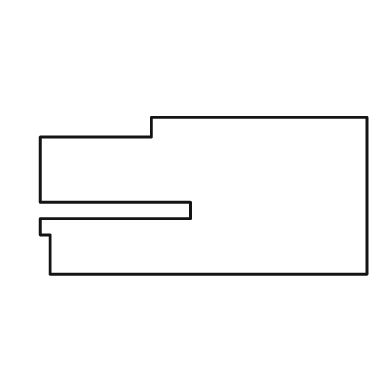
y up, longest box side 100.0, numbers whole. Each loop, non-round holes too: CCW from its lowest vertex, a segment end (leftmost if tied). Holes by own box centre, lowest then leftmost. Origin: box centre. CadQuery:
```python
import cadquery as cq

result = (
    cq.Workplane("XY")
    .moveTo(-47.0, -24.0)
    .lineTo(50.0, -24.0)
    .lineTo(50.0, 24.0)
    .lineTo(-16.0, 24.0)
    .lineTo(-16.0, 18.0)
    .lineTo(-50.0, 18.0)
    .lineTo(-50.0, -2.0)
    .lineTo(-4.0, -2.0)
    .lineTo(-4.0, -7.0)
    .lineTo(-50.0, -7.0)
    .lineTo(-50.0, -12.0)
    .lineTo(-47.0, -12.0)
    .close()
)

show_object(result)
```